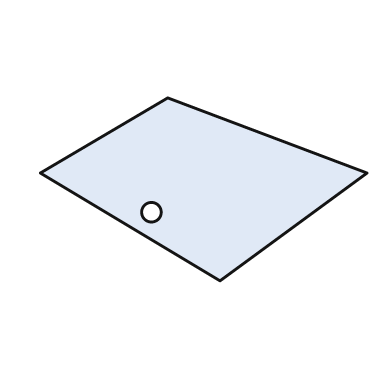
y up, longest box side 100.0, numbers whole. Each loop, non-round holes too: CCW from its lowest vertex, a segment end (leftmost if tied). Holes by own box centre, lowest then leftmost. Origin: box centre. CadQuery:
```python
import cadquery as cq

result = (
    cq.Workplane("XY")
    .moveTo(5.0, -28.0)
    .lineTo(50.0, 5.0)
    .lineTo(-11.0, 28.0)
    .lineTo(-50.0, 5.0)
    .close()
    .moveTo(-16.0, -7.0)
    .circle(3.0)
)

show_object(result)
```